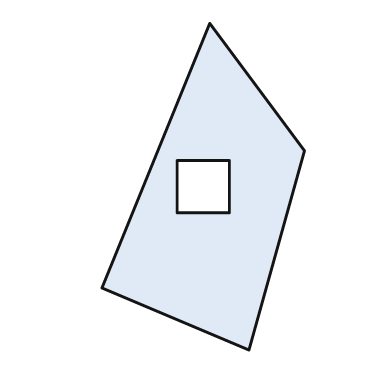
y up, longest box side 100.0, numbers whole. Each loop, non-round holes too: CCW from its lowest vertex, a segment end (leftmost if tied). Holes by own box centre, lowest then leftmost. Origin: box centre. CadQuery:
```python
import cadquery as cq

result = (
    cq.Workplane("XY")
    .moveTo(14.0, -50.0)
    .lineTo(31.0, 11.0)
    .lineTo(2.0, 50.0)
    .lineTo(-31.0, -31.0)
    .close()
    .moveTo(-8.0, -8.0)
    .lineTo(8.0, -8.0)
    .lineTo(8.0, 8.0)
    .lineTo(-8.0, 8.0)
    .close()
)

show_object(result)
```